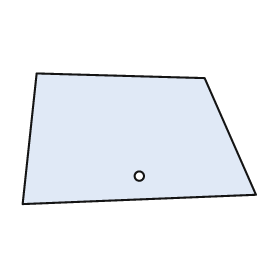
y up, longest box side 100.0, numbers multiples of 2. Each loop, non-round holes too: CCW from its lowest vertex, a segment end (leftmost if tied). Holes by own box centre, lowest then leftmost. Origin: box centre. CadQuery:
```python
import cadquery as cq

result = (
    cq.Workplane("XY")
    .moveTo(-50.0, -28.0)
    .lineTo(50.0, -24.0)
    .lineTo(28.0, 26.0)
    .lineTo(-44.0, 28.0)
    .close()
    .moveTo(0.0, -16.0)
    .circle(2.0)
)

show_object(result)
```